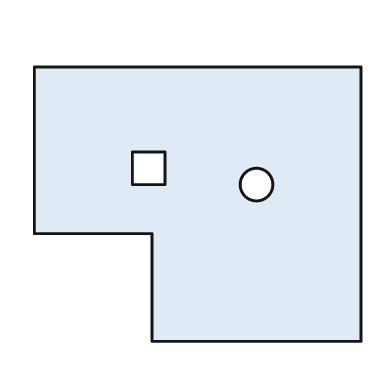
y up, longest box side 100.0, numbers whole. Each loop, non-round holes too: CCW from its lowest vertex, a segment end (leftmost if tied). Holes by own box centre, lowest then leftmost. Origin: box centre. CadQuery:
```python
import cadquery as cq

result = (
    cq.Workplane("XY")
    .moveTo(-14.0, -42.0)
    .lineTo(50.0, -42.0)
    .lineTo(50.0, 42.0)
    .lineTo(-50.0, 42.0)
    .lineTo(-50.0, -9.0)
    .lineTo(-14.0, -9.0)
    .close()
    .moveTo(18.0, 6.0)
    .circle(5.0)
    .moveTo(-20.0, 6.0)
    .lineTo(-10.0, 6.0)
    .lineTo(-10.0, 16.0)
    .lineTo(-20.0, 16.0)
    .close()
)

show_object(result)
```